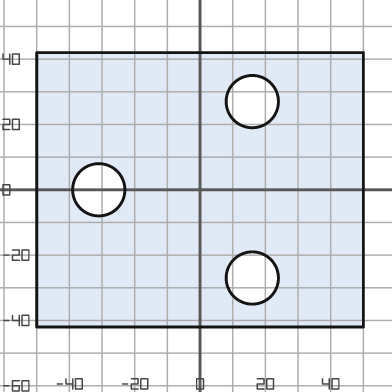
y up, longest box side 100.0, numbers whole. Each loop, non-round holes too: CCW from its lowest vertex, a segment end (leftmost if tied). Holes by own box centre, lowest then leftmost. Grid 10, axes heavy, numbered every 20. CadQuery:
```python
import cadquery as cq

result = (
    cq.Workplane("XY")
    .moveTo(-50.0, -42.0)
    .lineTo(50.0, -42.0)
    .lineTo(50.0, 42.0)
    .lineTo(-50.0, 42.0)
    .close()
    .moveTo(16.0, -27.0)
    .circle(8.0)
    .moveTo(-31.0, 0.0)
    .circle(8.0)
    .moveTo(16.0, 27.0)
    .circle(8.0)
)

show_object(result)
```